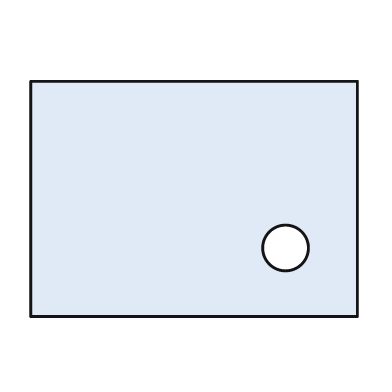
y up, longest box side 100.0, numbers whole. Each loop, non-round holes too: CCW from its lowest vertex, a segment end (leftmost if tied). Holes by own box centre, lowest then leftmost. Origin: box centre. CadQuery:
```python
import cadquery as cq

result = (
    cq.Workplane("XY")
    .moveTo(-50.0, -36.0)
    .lineTo(50.0, -36.0)
    .lineTo(50.0, 36.0)
    .lineTo(-50.0, 36.0)
    .close()
    .moveTo(28.0, -15.0)
    .circle(7.0)
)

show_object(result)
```